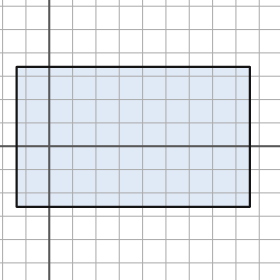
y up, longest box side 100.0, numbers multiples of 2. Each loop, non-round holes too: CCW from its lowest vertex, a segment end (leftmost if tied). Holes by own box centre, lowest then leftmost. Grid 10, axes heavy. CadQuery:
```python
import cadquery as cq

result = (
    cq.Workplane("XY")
    .moveTo(-14.0, -26.0)
    .lineTo(86.0, -26.0)
    .lineTo(86.0, 34.0)
    .lineTo(-14.0, 34.0)
    .close()
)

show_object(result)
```